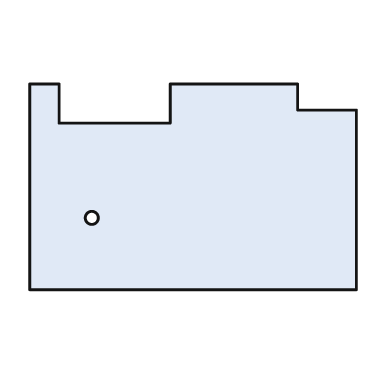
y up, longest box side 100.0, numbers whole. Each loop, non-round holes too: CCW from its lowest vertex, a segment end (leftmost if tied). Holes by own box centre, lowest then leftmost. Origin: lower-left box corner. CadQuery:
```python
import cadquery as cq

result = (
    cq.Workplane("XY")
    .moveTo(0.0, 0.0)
    .lineTo(100.0, 0.0)
    .lineTo(100.0, 55.0)
    .lineTo(82.0, 55.0)
    .lineTo(82.0, 63.0)
    .lineTo(43.0, 63.0)
    .lineTo(43.0, 51.0)
    .lineTo(9.0, 51.0)
    .lineTo(9.0, 63.0)
    .lineTo(0.0, 63.0)
    .close()
    .moveTo(19.0, 22.0)
    .circle(2.0)
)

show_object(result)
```